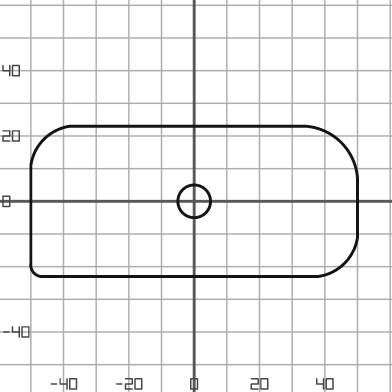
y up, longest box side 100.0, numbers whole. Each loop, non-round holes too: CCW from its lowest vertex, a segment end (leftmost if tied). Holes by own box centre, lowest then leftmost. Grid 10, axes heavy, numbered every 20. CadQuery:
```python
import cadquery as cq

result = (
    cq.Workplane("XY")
    .moveTo(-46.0, -23.0)
    .lineTo(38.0, -23.0)
    .threePointArc((46.0, -19.0), (50.0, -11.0))
    .lineTo(50.0, 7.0)
    .threePointArc((45.0, 18.0), (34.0, 23.0))
    .lineTo(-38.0, 23.0)
    .threePointArc((-46.0, 19.0), (-50.0, 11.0))
    .lineTo(-50.0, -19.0)
    .threePointArc((-49.0, -22.0), (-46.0, -23.0))
    .close()
    .moveTo(0.0, 0.0)
    .circle(5.0)
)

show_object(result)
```